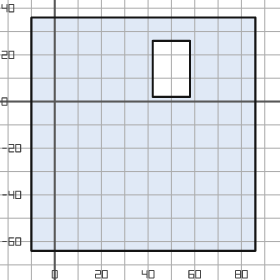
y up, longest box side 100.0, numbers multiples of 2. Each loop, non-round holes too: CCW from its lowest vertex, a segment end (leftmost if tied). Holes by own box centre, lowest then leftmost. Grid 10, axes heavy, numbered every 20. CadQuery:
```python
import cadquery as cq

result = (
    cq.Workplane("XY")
    .moveTo(-10.0, -64.0)
    .lineTo(86.0, -64.0)
    .lineTo(86.0, 36.0)
    .lineTo(-10.0, 36.0)
    .close()
    .moveTo(42.0, 2.0)
    .lineTo(58.0, 2.0)
    .lineTo(58.0, 26.0)
    .lineTo(42.0, 26.0)
    .close()
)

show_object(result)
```